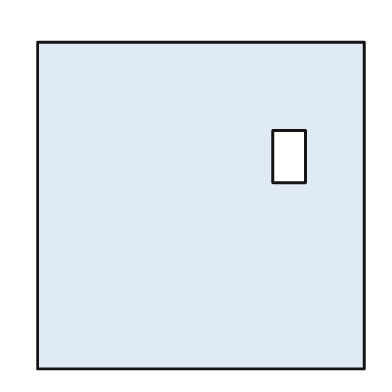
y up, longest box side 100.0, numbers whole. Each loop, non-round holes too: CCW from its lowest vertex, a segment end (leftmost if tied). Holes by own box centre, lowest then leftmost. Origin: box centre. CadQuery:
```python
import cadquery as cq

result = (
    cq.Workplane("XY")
    .moveTo(-50.0, -50.0)
    .lineTo(50.0, -50.0)
    .lineTo(50.0, 50.0)
    .lineTo(-50.0, 50.0)
    .close()
    .moveTo(22.0, 7.0)
    .lineTo(32.0, 7.0)
    .lineTo(32.0, 23.0)
    .lineTo(22.0, 23.0)
    .close()
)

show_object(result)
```